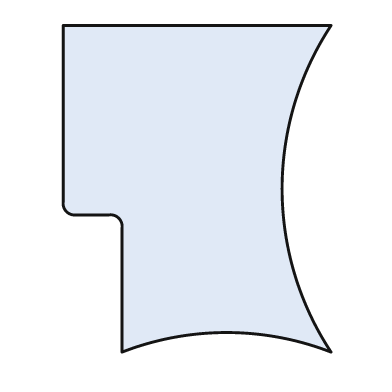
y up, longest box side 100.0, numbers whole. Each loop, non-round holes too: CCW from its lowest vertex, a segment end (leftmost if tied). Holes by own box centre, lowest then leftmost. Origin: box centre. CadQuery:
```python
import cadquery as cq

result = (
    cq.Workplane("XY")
    .moveTo(-23.0, -50.0)
    .threePointArc((9.0, -44.0), (41.0, -50.0))
    .threePointArc((26.0, 0.0), (41.0, 50.0))
    .lineTo(-41.0, 50.0)
    .lineTo(-41.0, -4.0)
    .threePointArc((-40.0, -7.0), (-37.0, -8.0))
    .lineTo(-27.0, -8.0)
    .threePointArc((-24.0, -9.0), (-23.0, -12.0))
    .close()
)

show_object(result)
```